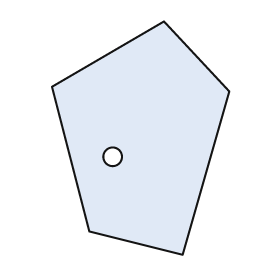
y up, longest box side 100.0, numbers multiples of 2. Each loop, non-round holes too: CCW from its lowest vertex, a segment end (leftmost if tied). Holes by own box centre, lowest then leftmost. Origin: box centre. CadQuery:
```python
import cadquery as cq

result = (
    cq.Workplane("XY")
    .moveTo(18.0, -50.0)
    .lineTo(38.0, 20.0)
    .lineTo(10.0, 50.0)
    .lineTo(-38.0, 22.0)
    .lineTo(-22.0, -40.0)
    .close()
    .moveTo(-12.0, -8.0)
    .circle(4.0)
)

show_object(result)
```